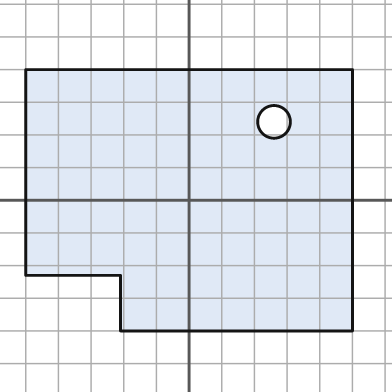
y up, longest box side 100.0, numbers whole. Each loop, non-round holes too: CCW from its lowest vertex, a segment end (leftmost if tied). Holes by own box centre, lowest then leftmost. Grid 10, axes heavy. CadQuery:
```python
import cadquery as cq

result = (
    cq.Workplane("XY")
    .moveTo(-21.0, -40.0)
    .lineTo(50.0, -40.0)
    .lineTo(50.0, 40.0)
    .lineTo(-50.0, 40.0)
    .lineTo(-50.0, -23.0)
    .lineTo(-21.0, -23.0)
    .close()
    .moveTo(26.0, 24.0)
    .circle(5.0)
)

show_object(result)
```